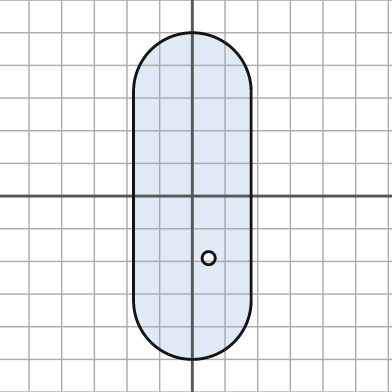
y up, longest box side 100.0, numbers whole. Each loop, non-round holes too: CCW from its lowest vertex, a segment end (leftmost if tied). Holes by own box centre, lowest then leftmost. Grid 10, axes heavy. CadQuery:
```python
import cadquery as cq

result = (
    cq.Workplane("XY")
    .moveTo(-18.0, -32.0)
    .threePointArc((0.0, -50.0), (18.0, -32.0))
    .lineTo(18.0, 32.0)
    .threePointArc((0.0, 50.0), (-18.0, 32.0))
    .close()
    .moveTo(5.0, -19.0)
    .circle(2.0)
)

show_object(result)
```